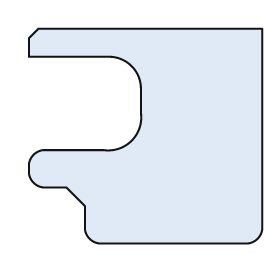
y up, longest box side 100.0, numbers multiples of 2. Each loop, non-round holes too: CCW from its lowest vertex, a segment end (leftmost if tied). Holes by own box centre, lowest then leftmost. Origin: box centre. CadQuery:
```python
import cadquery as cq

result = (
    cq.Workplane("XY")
    .moveTo(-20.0, -46.0)
    .lineTo(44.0, -46.0)
    .threePointArc((48.0, -44.0), (50.0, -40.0))
    .lineTo(50.0, 46.0)
    .lineTo(-46.0, 46.0)
    .lineTo(-50.0, 42.0)
    .lineTo(-50.0, 34.0)
    .lineTo(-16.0, 34.0)
    .threePointArc((-6.0, 30.0), (-2.0, 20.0))
    .lineTo(-2.0, 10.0)
    .threePointArc((-6.0, -2.0), (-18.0, -6.0))
    .lineTo(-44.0, -6.0)
    .threePointArc((-48.0, -8.0), (-50.0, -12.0))
    .lineTo(-50.0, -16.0)
    .threePointArc((-48.0, -20.0), (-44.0, -22.0))
    .lineTo(-34.0, -22.0)
    .lineTo(-26.0, -30.0)
    .lineTo(-26.0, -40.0)
    .threePointArc((-24.0, -44.0), (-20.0, -46.0))
    .close()
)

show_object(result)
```